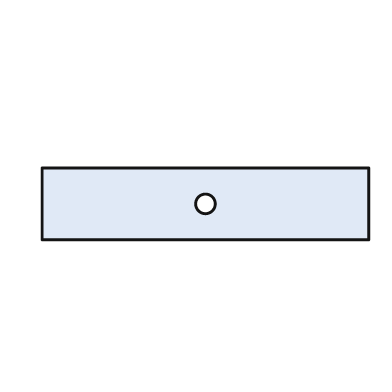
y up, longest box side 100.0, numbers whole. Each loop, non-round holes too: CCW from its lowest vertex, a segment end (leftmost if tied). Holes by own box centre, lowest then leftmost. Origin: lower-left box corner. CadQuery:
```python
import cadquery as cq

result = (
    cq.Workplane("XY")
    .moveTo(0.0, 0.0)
    .lineTo(100.0, 0.0)
    .lineTo(100.0, 22.0)
    .lineTo(0.0, 22.0)
    .close()
    .moveTo(50.0, 11.0)
    .circle(3.0)
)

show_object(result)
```